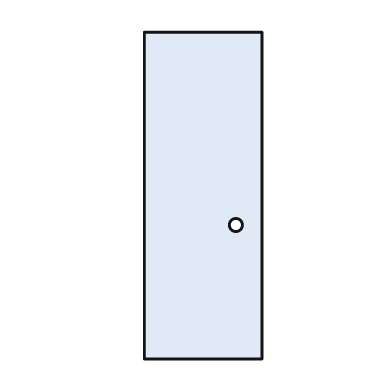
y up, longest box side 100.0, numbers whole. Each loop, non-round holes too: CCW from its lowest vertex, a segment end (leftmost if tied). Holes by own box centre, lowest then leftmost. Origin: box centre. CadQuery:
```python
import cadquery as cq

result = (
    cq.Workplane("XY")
    .moveTo(-18.0, -50.0)
    .lineTo(18.0, -50.0)
    .lineTo(18.0, 50.0)
    .lineTo(-18.0, 50.0)
    .close()
    .moveTo(10.0, -9.0)
    .circle(2.0)
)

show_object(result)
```